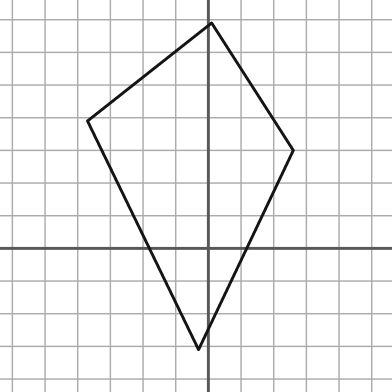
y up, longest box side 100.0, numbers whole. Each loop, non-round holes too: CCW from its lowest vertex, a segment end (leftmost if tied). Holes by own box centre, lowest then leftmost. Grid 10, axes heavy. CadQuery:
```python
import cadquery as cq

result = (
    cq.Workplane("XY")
    .moveTo(-3.0, -31.0)
    .lineTo(26.0, 30.0)
    .lineTo(1.0, 69.0)
    .lineTo(-37.0, 39.0)
    .close()
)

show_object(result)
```